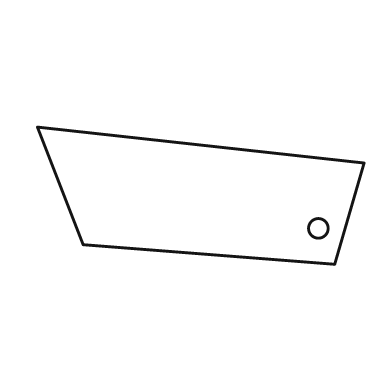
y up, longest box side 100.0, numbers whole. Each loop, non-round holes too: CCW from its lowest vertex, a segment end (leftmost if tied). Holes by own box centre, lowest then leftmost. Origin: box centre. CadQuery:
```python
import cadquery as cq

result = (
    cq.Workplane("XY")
    .moveTo(41.0, -21.0)
    .lineTo(50.0, 10.0)
    .lineTo(-50.0, 21.0)
    .lineTo(-36.0, -15.0)
    .close()
    .moveTo(36.0, -10.0)
    .circle(3.0)
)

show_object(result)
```